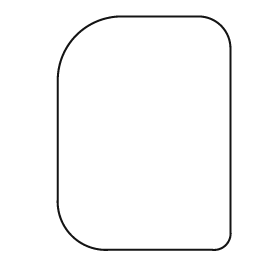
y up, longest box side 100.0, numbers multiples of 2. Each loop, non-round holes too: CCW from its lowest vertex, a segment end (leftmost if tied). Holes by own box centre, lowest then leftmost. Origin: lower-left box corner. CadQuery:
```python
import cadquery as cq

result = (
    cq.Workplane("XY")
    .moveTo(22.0, 0.0)
    .lineTo(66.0, 0.0)
    .threePointArc((72.0, 2.0), (74.0, 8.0))
    .lineTo(74.0, 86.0)
    .threePointArc((70.0, 96.0), (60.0, 100.0))
    .lineTo(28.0, 100.0)
    .threePointArc((8.0, 92.0), (0.0, 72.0))
    .lineTo(0.0, 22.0)
    .threePointArc((6.0, 6.0), (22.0, 0.0))
    .close()
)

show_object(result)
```